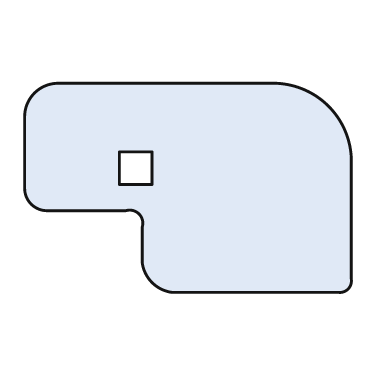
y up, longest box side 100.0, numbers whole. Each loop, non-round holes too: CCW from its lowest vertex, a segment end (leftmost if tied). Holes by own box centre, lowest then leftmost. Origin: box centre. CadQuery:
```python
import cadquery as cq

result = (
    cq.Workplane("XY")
    .moveTo(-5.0, -32.0)
    .lineTo(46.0, -32.0)
    .threePointArc((49.0, -31.0), (50.0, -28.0))
    .lineTo(50.0, 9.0)
    .threePointArc((43.0, 25.0), (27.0, 32.0))
    .lineTo(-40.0, 32.0)
    .threePointArc((-47.0, 29.0), (-50.0, 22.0))
    .lineTo(-50.0, 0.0)
    .threePointArc((-48.0, -5.0), (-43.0, -7.0))
    .lineTo(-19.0, -7.0)
    .threePointArc((-15.0, -8.0), (-14.0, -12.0))
    .lineTo(-14.0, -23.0)
    .threePointArc((-11.0, -29.0), (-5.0, -32.0))
    .close()
    .moveTo(-21.0, 1.0)
    .lineTo(-11.0, 1.0)
    .lineTo(-11.0, 11.0)
    .lineTo(-21.0, 11.0)
    .close()
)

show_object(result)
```